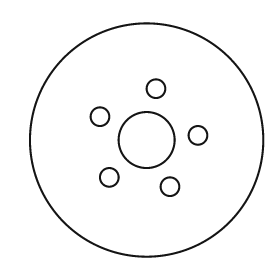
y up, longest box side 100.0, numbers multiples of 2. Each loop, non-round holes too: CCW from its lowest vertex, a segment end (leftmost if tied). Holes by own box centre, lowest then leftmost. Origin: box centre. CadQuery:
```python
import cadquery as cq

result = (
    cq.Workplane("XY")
    .moveTo(0.0, 0.0)
    .circle(50.0)
    .moveTo(10.0, -20.0)
    .circle(4.0)
    .moveTo(-16.0, -16.0)
    .circle(4.0)
    .moveTo(0.0, 0.0)
    .circle(12.0)
    .moveTo(22.0, 2.0)
    .circle(4.0)
    .moveTo(-20.0, 10.0)
    .circle(4.0)
    .moveTo(4.0, 22.0)
    .circle(4.0)
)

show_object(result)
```